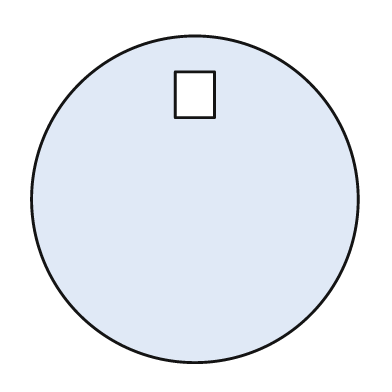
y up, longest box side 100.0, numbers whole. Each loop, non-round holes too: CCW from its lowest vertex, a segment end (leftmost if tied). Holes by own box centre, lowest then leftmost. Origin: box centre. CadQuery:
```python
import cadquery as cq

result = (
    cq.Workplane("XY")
    .moveTo(0.0, 0.0)
    .circle(50.0)
    .moveTo(-6.0, 25.0)
    .lineTo(6.0, 25.0)
    .lineTo(6.0, 39.0)
    .lineTo(-6.0, 39.0)
    .close()
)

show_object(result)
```